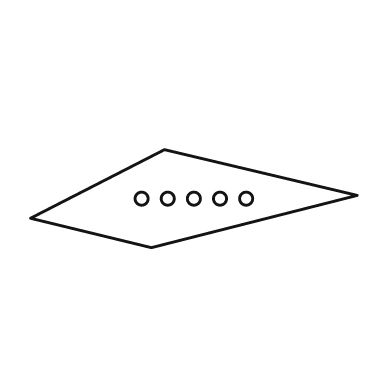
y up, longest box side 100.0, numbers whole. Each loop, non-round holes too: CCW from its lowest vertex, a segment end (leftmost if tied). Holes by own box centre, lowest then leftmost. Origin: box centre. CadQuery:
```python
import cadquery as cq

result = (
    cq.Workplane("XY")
    .moveTo(-13.0, -15.0)
    .lineTo(50.0, 1.0)
    .lineTo(-9.0, 15.0)
    .lineTo(-50.0, -6.0)
    .close()
    .moveTo(-16.0, 0.0)
    .circle(2.0)
    .moveTo(-8.0, 0.0)
    .circle(2.0)
    .moveTo(0.0, 0.0)
    .circle(2.0)
    .moveTo(8.0, 0.0)
    .circle(2.0)
    .moveTo(16.0, 0.0)
    .circle(2.0)
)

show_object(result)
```